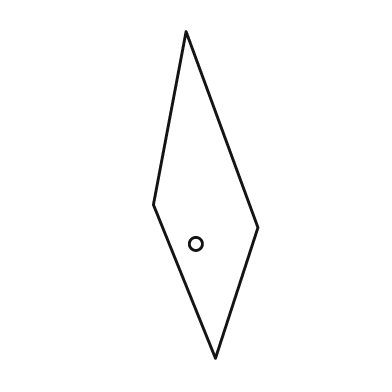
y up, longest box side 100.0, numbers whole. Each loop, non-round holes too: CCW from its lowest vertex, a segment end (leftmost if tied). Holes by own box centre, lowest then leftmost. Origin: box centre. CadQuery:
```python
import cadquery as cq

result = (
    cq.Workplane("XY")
    .moveTo(3.0, -50.0)
    .lineTo(16.0, -10.0)
    .lineTo(-6.0, 50.0)
    .lineTo(-16.0, -3.0)
    .close()
    .moveTo(-3.0, -15.0)
    .circle(2.0)
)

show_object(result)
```